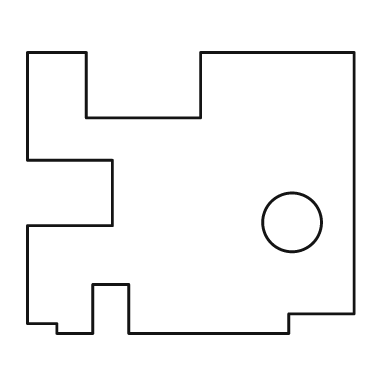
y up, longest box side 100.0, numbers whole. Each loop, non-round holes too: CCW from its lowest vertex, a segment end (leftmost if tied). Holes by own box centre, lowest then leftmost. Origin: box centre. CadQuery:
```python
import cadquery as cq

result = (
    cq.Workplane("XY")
    .moveTo(-41.0, -43.0)
    .lineTo(-30.0, -43.0)
    .lineTo(-30.0, -28.0)
    .lineTo(-19.0, -28.0)
    .lineTo(-19.0, -43.0)
    .lineTo(30.0, -43.0)
    .lineTo(30.0, -37.0)
    .lineTo(50.0, -37.0)
    .lineTo(50.0, 43.0)
    .lineTo(3.0, 43.0)
    .lineTo(3.0, 23.0)
    .lineTo(-32.0, 23.0)
    .lineTo(-32.0, 43.0)
    .lineTo(-50.0, 43.0)
    .lineTo(-50.0, 10.0)
    .lineTo(-24.0, 10.0)
    .lineTo(-24.0, -10.0)
    .lineTo(-50.0, -10.0)
    .lineTo(-50.0, -40.0)
    .lineTo(-41.0, -40.0)
    .close()
    .moveTo(31.0, -9.0)
    .circle(9.0)
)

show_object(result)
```